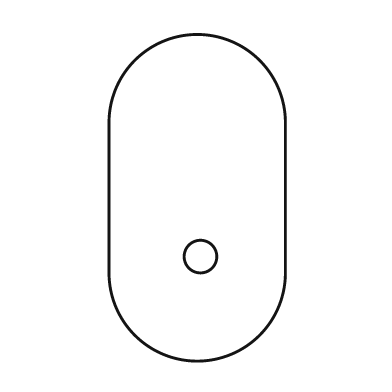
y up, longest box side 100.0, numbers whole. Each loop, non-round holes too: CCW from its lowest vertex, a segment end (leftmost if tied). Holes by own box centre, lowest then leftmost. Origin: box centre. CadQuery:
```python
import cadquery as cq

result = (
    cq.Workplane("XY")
    .moveTo(-27.0, -23.0)
    .threePointArc((0.0, -50.0), (27.0, -23.0))
    .lineTo(27.0, 23.0)
    .threePointArc((0.0, 50.0), (-27.0, 23.0))
    .close()
    .moveTo(1.0, -18.0)
    .circle(5.0)
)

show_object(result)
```